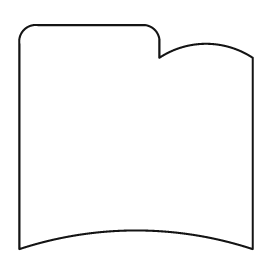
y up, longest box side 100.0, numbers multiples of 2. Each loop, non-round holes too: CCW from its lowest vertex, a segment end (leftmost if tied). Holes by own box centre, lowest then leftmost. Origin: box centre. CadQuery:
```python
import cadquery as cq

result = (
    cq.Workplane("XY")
    .moveTo(-50.0, -48.0)
    .threePointArc((0.0, -40.0), (50.0, -48.0))
    .lineTo(50.0, 34.0)
    .threePointArc((30.0, 40.0), (10.0, 34.0))
    .lineTo(10.0, 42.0)
    .threePointArc((8.0, 46.0), (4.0, 48.0))
    .lineTo(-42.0, 48.0)
    .threePointArc((-48.0, 46.0), (-50.0, 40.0))
    .close()
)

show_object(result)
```